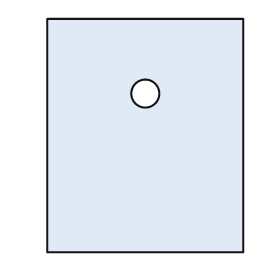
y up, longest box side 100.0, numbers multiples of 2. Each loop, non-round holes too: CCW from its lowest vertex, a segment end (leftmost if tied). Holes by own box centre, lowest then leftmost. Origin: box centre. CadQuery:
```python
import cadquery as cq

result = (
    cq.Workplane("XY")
    .moveTo(-42.0, -50.0)
    .lineTo(42.0, -50.0)
    .lineTo(42.0, 50.0)
    .lineTo(-42.0, 50.0)
    .close()
    .moveTo(0.0, 18.0)
    .circle(6.0)
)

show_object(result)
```